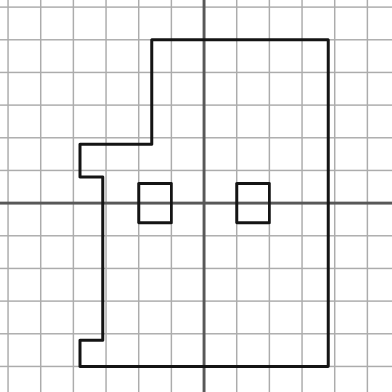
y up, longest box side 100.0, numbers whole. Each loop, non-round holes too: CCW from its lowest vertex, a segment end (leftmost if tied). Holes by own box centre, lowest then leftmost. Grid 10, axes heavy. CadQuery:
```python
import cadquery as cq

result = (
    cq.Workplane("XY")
    .moveTo(-38.0, -50.0)
    .lineTo(38.0, -50.0)
    .lineTo(38.0, 50.0)
    .lineTo(-16.0, 50.0)
    .lineTo(-16.0, 18.0)
    .lineTo(-38.0, 18.0)
    .lineTo(-38.0, 8.0)
    .lineTo(-31.0, 8.0)
    .lineTo(-31.0, -42.0)
    .lineTo(-38.0, -42.0)
    .close()
    .moveTo(-20.0, -6.0)
    .lineTo(-10.0, -6.0)
    .lineTo(-10.0, 6.0)
    .lineTo(-20.0, 6.0)
    .close()
    .moveTo(10.0, -6.0)
    .lineTo(20.0, -6.0)
    .lineTo(20.0, 6.0)
    .lineTo(10.0, 6.0)
    .close()
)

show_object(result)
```